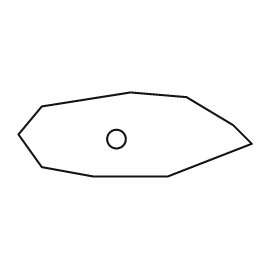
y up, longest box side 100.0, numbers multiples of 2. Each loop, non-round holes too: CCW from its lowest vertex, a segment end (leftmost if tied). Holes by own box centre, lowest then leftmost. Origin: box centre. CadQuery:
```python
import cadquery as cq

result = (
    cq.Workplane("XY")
    .moveTo(-18.0, -18.0)
    .lineTo(14.0, -18.0)
    .lineTo(50.0, -4.0)
    .lineTo(42.0, 4.0)
    .lineTo(22.0, 16.0)
    .lineTo(-2.0, 18.0)
    .lineTo(-40.0, 12.0)
    .lineTo(-50.0, 0.0)
    .lineTo(-40.0, -14.0)
    .close()
    .moveTo(-8.0, -2.0)
    .circle(4.0)
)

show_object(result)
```